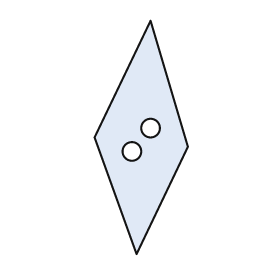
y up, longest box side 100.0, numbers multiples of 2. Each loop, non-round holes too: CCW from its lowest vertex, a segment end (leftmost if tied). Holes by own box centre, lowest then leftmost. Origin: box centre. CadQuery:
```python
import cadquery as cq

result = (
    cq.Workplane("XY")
    .moveTo(-2.0, -50.0)
    .lineTo(20.0, -4.0)
    .lineTo(4.0, 50.0)
    .lineTo(-20.0, 0.0)
    .close()
    .moveTo(-4.0, -6.0)
    .circle(4.0)
    .moveTo(4.0, 4.0)
    .circle(4.0)
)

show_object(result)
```